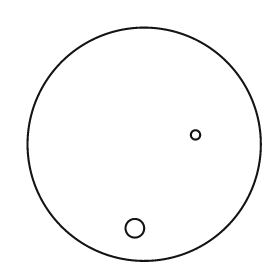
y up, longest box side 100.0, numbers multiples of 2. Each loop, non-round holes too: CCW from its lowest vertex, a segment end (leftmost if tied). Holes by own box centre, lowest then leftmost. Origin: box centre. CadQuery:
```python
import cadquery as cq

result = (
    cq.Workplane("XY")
    .moveTo(0.0, 0.0)
    .circle(50.0)
    .moveTo(-4.0, -36.0)
    .circle(4.0)
    .moveTo(22.0, 4.0)
    .circle(2.0)
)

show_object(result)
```